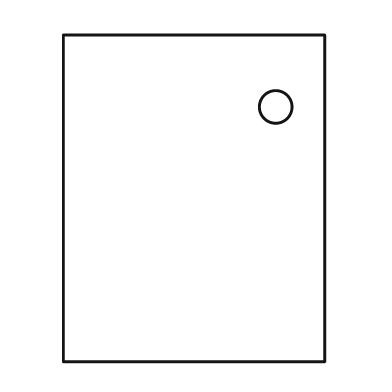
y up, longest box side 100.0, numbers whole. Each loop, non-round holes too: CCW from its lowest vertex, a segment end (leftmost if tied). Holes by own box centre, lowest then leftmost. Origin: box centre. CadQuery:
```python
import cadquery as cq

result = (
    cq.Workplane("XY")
    .moveTo(-40.0, -50.0)
    .lineTo(40.0, -50.0)
    .lineTo(40.0, 50.0)
    .lineTo(-40.0, 50.0)
    .close()
    .moveTo(25.0, 28.0)
    .circle(5.0)
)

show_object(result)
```